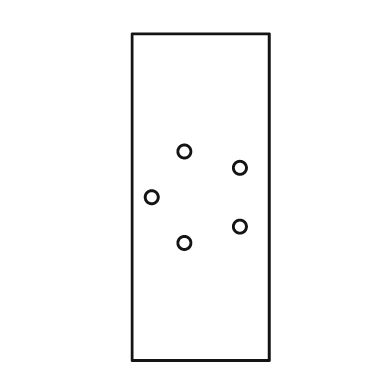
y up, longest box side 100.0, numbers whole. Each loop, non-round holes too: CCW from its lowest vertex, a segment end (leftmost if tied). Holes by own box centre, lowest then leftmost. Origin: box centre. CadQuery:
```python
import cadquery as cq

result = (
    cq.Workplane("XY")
    .moveTo(-21.0, -50.0)
    .lineTo(21.0, -50.0)
    .lineTo(21.0, 50.0)
    .lineTo(-21.0, 50.0)
    .close()
    .moveTo(-5.0, -14.0)
    .circle(2.0)
    .moveTo(12.0, -9.0)
    .circle(2.0)
    .moveTo(-15.0, 0.0)
    .circle(2.0)
    .moveTo(12.0, 9.0)
    .circle(2.0)
    .moveTo(-5.0, 14.0)
    .circle(2.0)
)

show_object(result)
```